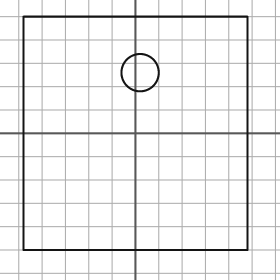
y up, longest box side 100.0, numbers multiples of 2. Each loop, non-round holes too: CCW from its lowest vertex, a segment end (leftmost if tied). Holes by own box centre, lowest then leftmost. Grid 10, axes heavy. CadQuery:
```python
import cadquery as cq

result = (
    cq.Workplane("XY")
    .moveTo(-48.0, -50.0)
    .lineTo(48.0, -50.0)
    .lineTo(48.0, 50.0)
    .lineTo(-48.0, 50.0)
    .close()
    .moveTo(2.0, 26.0)
    .circle(8.0)
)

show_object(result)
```